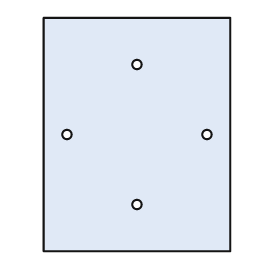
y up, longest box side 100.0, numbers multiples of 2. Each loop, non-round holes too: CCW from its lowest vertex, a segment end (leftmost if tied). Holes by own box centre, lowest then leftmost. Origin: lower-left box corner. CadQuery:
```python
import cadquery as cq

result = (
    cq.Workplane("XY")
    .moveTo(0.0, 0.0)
    .lineTo(80.0, 0.0)
    .lineTo(80.0, 100.0)
    .lineTo(0.0, 100.0)
    .close()
    .moveTo(40.0, 20.0)
    .circle(2.0)
    .moveTo(10.0, 50.0)
    .circle(2.0)
    .moveTo(70.0, 50.0)
    .circle(2.0)
    .moveTo(40.0, 80.0)
    .circle(2.0)
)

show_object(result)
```